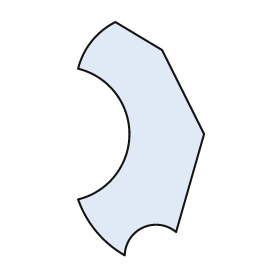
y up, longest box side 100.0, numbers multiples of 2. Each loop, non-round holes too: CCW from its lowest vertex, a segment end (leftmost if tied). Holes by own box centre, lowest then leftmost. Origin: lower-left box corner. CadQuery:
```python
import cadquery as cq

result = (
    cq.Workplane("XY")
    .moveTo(20.0, 0.0)
    .threePointArc((28.0, 12.0), (42.0, 10.0))
    .lineTo(54.0, 52.0)
    .lineTo(36.0, 88.0)
    .lineTo(16.0, 100.0)
    .threePointArc((6.0, 92.0), (0.0, 80.0))
    .threePointArc((22.0, 52.0), (0.0, 24.0))
    .threePointArc((8.0, 10.0), (20.0, 0.0))
    .close()
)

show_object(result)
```